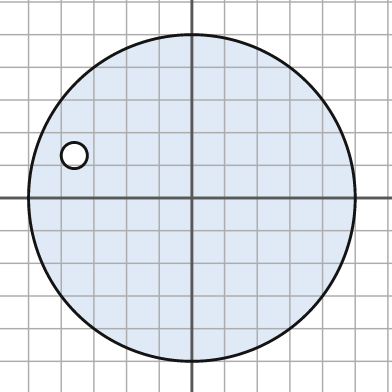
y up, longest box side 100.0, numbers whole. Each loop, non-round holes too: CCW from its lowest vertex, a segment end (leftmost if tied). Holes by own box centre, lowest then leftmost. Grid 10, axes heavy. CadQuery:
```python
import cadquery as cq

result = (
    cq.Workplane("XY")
    .moveTo(0.0, 0.0)
    .circle(50.0)
    .moveTo(-36.0, 13.0)
    .circle(4.0)
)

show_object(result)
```